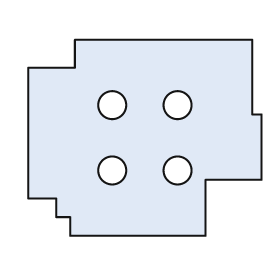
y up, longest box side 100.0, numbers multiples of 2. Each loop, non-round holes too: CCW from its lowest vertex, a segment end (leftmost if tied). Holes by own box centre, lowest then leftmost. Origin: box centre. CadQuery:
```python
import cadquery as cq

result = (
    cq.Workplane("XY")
    .moveTo(-32.0, -42.0)
    .lineTo(26.0, -42.0)
    .lineTo(26.0, -18.0)
    .lineTo(50.0, -18.0)
    .lineTo(50.0, 10.0)
    .lineTo(46.0, 10.0)
    .lineTo(46.0, 42.0)
    .lineTo(-30.0, 42.0)
    .lineTo(-30.0, 30.0)
    .lineTo(-50.0, 30.0)
    .lineTo(-50.0, -26.0)
    .lineTo(-38.0, -26.0)
    .lineTo(-38.0, -34.0)
    .lineTo(-32.0, -34.0)
    .close()
    .moveTo(-14.0, -14.0)
    .circle(6.0)
    .moveTo(14.0, -14.0)
    .circle(6.0)
    .moveTo(-14.0, 14.0)
    .circle(6.0)
    .moveTo(14.0, 14.0)
    .circle(6.0)
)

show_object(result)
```